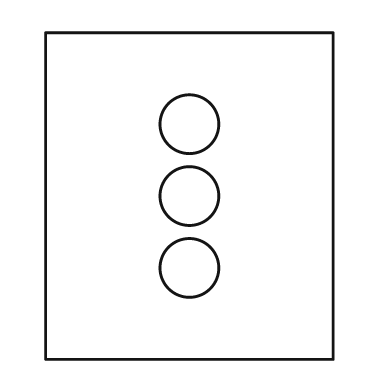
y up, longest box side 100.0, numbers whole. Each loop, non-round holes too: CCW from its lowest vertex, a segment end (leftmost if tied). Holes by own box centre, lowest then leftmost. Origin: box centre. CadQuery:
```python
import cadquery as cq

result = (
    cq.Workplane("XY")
    .moveTo(-44.0, -50.0)
    .lineTo(44.0, -50.0)
    .lineTo(44.0, 50.0)
    .lineTo(-44.0, 50.0)
    .close()
    .moveTo(0.0, -22.0)
    .circle(9.0)
    .moveTo(0.0, 0.0)
    .circle(9.0)
    .moveTo(0.0, 22.0)
    .circle(9.0)
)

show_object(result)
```